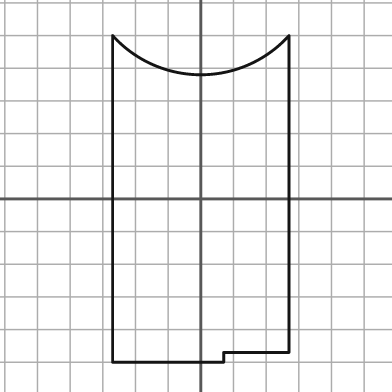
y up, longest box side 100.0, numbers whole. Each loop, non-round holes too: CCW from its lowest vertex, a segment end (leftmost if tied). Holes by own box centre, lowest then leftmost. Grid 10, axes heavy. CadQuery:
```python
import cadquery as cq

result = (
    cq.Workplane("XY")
    .moveTo(-27.0, -50.0)
    .lineTo(7.0, -50.0)
    .lineTo(7.0, -47.0)
    .lineTo(27.0, -47.0)
    .lineTo(27.0, 50.0)
    .threePointArc((0.0, 38.0), (-27.0, 50.0))
    .close()
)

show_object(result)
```